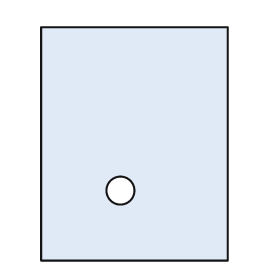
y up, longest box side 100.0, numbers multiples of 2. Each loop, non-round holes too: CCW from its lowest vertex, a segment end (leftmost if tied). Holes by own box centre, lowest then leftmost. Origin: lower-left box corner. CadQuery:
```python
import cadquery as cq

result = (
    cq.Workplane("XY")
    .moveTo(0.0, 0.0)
    .lineTo(80.0, 0.0)
    .lineTo(80.0, 100.0)
    .lineTo(0.0, 100.0)
    .close()
    .moveTo(34.0, 30.0)
    .circle(6.0)
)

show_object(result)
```